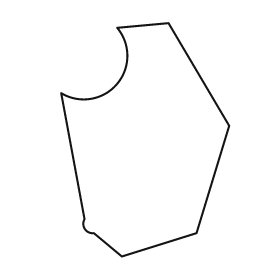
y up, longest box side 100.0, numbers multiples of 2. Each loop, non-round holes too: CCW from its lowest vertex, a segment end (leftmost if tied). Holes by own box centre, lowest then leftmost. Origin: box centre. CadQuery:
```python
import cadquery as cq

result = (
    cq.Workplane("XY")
    .moveTo(-10.0, -50.0)
    .lineTo(22.0, -40.0)
    .lineTo(36.0, 6.0)
    .lineTo(10.0, 50.0)
    .lineTo(-12.0, 48.0)
    .threePointArc((-12.0, 24.0), (-36.0, 20.0))
    .lineTo(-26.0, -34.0)
    .threePointArc((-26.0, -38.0), (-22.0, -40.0))
    .close()
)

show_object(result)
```